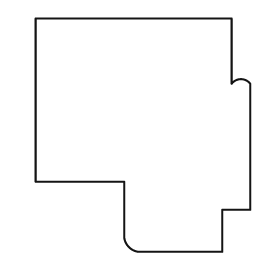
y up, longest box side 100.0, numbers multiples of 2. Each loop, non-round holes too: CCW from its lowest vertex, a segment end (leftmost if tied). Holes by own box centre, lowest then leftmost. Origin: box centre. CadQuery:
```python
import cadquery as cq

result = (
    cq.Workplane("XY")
    .moveTo(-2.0, -50.0)
    .lineTo(34.0, -50.0)
    .lineTo(34.0, -32.0)
    .lineTo(46.0, -32.0)
    .lineTo(46.0, 22.0)
    .threePointArc((42.0, 24.0), (38.0, 22.0))
    .lineTo(38.0, 50.0)
    .lineTo(-46.0, 50.0)
    .lineTo(-46.0, -20.0)
    .lineTo(-8.0, -20.0)
    .lineTo(-8.0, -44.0)
    .threePointArc((-6.0, -48.0), (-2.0, -50.0))
    .close()
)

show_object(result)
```